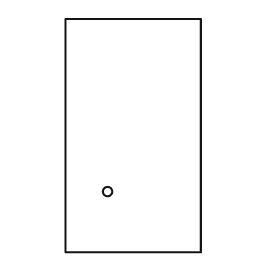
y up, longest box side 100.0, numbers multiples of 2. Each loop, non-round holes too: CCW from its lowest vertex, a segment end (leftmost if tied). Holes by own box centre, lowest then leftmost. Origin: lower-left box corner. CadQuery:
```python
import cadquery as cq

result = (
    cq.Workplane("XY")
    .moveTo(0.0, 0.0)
    .lineTo(58.0, 0.0)
    .lineTo(58.0, 100.0)
    .lineTo(0.0, 100.0)
    .close()
    .moveTo(18.0, 26.0)
    .circle(2.0)
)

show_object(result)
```